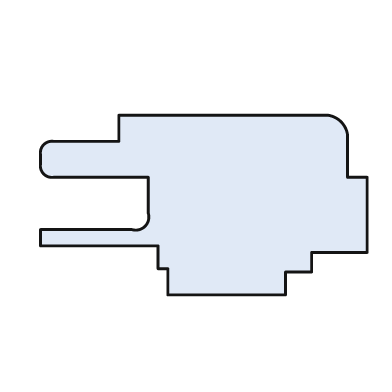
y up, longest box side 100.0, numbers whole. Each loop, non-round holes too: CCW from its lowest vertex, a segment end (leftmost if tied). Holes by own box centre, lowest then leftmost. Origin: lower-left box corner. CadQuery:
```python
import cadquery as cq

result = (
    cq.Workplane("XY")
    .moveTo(39.0, 0.0)
    .lineTo(75.0, 0.0)
    .lineTo(75.0, 7.0)
    .lineTo(83.0, 7.0)
    .lineTo(83.0, 13.0)
    .lineTo(100.0, 13.0)
    .lineTo(100.0, 36.0)
    .lineTo(94.0, 36.0)
    .lineTo(94.0, 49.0)
    .threePointArc((92.0, 53.0), (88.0, 55.0))
    .lineTo(24.0, 55.0)
    .lineTo(24.0, 47.0)
    .lineTo(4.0, 47.0)
    .threePointArc((1.0, 46.0), (0.0, 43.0))
    .lineTo(0.0, 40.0)
    .threePointArc((1.0, 37.0), (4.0, 36.0))
    .lineTo(33.0, 36.0)
    .lineTo(33.0, 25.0)
    .threePointArc((32.0, 21.0), (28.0, 20.0))
    .lineTo(0.0, 20.0)
    .lineTo(0.0, 15.0)
    .lineTo(36.0, 15.0)
    .lineTo(36.0, 8.0)
    .lineTo(39.0, 8.0)
    .close()
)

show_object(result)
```